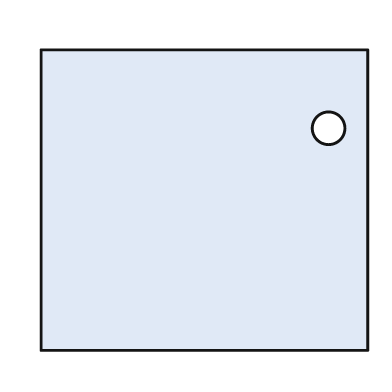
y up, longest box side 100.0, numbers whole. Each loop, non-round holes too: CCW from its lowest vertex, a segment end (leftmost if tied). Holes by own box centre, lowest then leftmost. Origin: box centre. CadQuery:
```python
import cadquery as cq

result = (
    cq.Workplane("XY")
    .moveTo(-50.0, -46.0)
    .lineTo(50.0, -46.0)
    .lineTo(50.0, 46.0)
    .lineTo(-50.0, 46.0)
    .close()
    .moveTo(38.0, 22.0)
    .circle(5.0)
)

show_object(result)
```